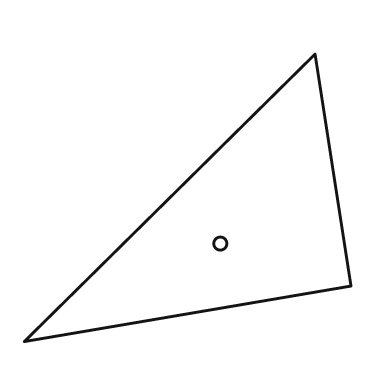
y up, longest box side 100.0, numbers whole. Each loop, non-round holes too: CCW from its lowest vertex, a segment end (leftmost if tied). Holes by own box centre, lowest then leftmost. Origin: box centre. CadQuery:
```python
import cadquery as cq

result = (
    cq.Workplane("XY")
    .moveTo(-50.0, -44.0)
    .lineTo(50.0, -27.0)
    .lineTo(39.0, 44.0)
    .close()
    .moveTo(10.0, -14.0)
    .circle(2.0)
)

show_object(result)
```